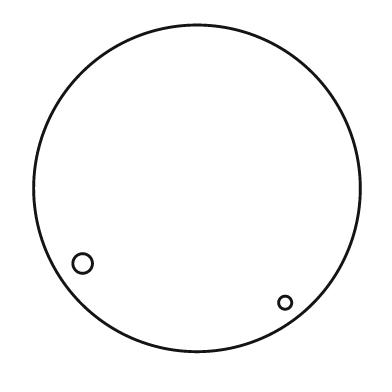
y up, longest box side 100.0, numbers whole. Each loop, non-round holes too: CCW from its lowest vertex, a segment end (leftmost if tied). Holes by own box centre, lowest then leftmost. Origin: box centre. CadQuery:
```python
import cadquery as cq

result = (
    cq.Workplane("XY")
    .moveTo(0.0, 0.0)
    .circle(50.0)
    .moveTo(27.0, -35.0)
    .circle(2.0)
    .moveTo(-35.0, -23.0)
    .circle(3.0)
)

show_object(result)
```